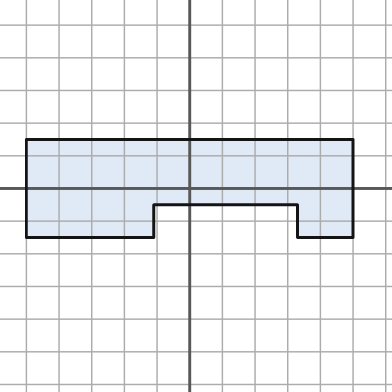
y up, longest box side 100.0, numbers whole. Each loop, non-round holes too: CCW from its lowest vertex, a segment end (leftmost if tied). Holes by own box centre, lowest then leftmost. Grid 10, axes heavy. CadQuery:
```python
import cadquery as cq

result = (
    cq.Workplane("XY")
    .moveTo(-50.0, -15.0)
    .lineTo(-11.0, -15.0)
    .lineTo(-11.0, -5.0)
    .lineTo(33.0, -5.0)
    .lineTo(33.0, -15.0)
    .lineTo(50.0, -15.0)
    .lineTo(50.0, 15.0)
    .lineTo(-50.0, 15.0)
    .close()
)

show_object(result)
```